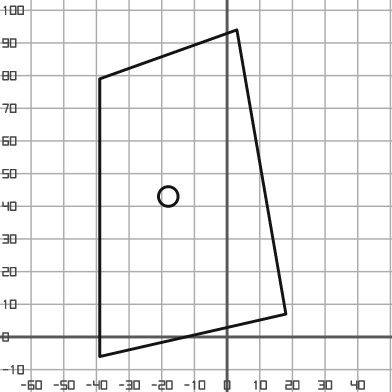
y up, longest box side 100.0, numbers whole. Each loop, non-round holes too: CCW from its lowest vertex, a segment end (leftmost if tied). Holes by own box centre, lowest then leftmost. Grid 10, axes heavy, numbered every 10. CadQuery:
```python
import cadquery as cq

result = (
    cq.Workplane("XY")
    .moveTo(-39.0, -6.0)
    .lineTo(18.0, 7.0)
    .lineTo(3.0, 94.0)
    .lineTo(-39.0, 79.0)
    .close()
    .moveTo(-18.0, 43.0)
    .circle(3.0)
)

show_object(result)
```